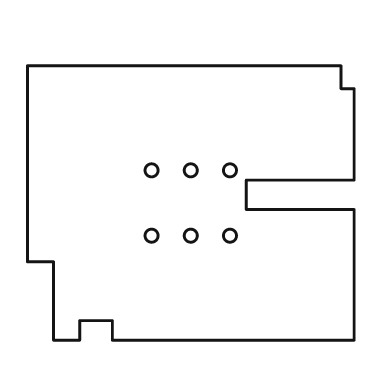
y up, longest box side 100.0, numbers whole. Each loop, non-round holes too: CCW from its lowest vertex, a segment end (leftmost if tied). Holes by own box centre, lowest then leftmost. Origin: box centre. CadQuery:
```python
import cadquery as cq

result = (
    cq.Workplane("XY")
    .moveTo(-42.0, -42.0)
    .lineTo(-34.0, -42.0)
    .lineTo(-34.0, -36.0)
    .lineTo(-24.0, -36.0)
    .lineTo(-24.0, -42.0)
    .lineTo(50.0, -42.0)
    .lineTo(50.0, -2.0)
    .lineTo(17.0, -2.0)
    .lineTo(17.0, 7.0)
    .lineTo(50.0, 7.0)
    .lineTo(50.0, 35.0)
    .lineTo(46.0, 35.0)
    .lineTo(46.0, 42.0)
    .lineTo(-50.0, 42.0)
    .lineTo(-50.0, -18.0)
    .lineTo(-42.0, -18.0)
    .close()
    .moveTo(-12.0, -10.0)
    .circle(2.0)
    .moveTo(0.0, -10.0)
    .circle(2.0)
    .moveTo(12.0, -10.0)
    .circle(2.0)
    .moveTo(-12.0, 10.0)
    .circle(2.0)
    .moveTo(0.0, 10.0)
    .circle(2.0)
    .moveTo(12.0, 10.0)
    .circle(2.0)
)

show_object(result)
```